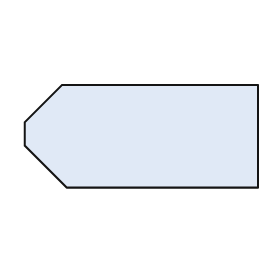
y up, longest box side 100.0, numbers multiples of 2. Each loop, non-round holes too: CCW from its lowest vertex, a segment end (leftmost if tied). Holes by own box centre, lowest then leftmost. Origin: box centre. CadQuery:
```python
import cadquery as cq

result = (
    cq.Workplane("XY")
    .moveTo(-32.0, -22.0)
    .lineTo(50.0, -22.0)
    .lineTo(50.0, 22.0)
    .lineTo(-34.0, 22.0)
    .lineTo(-50.0, 6.0)
    .lineTo(-50.0, -4.0)
    .close()
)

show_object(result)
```